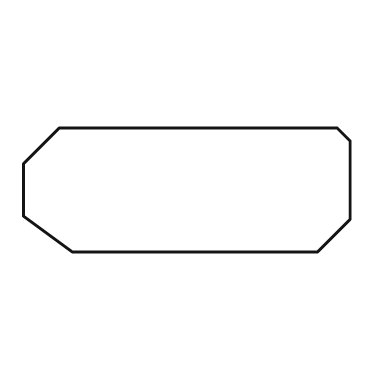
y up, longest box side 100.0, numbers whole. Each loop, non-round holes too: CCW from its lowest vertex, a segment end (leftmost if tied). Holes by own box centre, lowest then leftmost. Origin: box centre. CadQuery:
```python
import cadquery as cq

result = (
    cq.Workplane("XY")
    .moveTo(-35.0, -19.0)
    .lineTo(40.0, -19.0)
    .lineTo(50.0, -9.0)
    .lineTo(50.0, 15.0)
    .lineTo(46.0, 19.0)
    .lineTo(-39.0, 19.0)
    .lineTo(-50.0, 8.0)
    .lineTo(-50.0, -8.0)
    .close()
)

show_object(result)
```